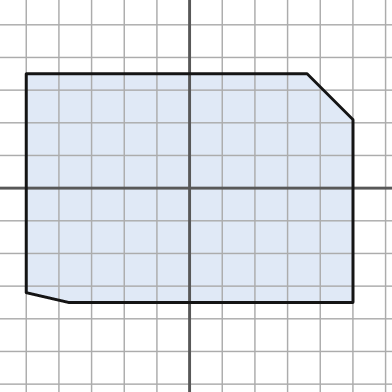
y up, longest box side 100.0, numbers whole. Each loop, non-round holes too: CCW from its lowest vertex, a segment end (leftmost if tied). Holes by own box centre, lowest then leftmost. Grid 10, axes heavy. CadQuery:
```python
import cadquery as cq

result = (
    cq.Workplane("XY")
    .moveTo(-37.0, -35.0)
    .lineTo(50.0, -35.0)
    .lineTo(50.0, 21.0)
    .lineTo(36.0, 35.0)
    .lineTo(-50.0, 35.0)
    .lineTo(-50.0, -32.0)
    .close()
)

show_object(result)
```